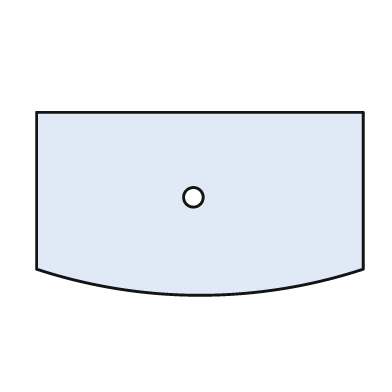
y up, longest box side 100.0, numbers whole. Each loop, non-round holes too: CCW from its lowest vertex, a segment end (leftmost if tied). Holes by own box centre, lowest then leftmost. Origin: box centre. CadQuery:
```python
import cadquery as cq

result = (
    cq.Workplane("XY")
    .moveTo(-50.0, -20.0)
    .threePointArc((0.0, -28.0), (50.0, -20.0))
    .lineTo(50.0, 28.0)
    .lineTo(-50.0, 28.0)
    .close()
    .moveTo(-2.0, 2.0)
    .circle(3.0)
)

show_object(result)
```